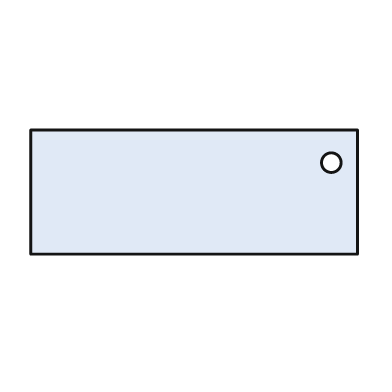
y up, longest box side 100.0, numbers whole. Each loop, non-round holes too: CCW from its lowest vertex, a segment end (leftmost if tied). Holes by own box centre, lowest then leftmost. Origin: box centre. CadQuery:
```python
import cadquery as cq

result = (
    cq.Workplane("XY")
    .moveTo(-50.0, -19.0)
    .lineTo(50.0, -19.0)
    .lineTo(50.0, 19.0)
    .lineTo(-50.0, 19.0)
    .close()
    .moveTo(42.0, 9.0)
    .circle(3.0)
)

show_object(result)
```